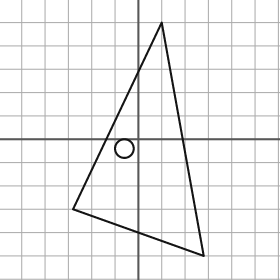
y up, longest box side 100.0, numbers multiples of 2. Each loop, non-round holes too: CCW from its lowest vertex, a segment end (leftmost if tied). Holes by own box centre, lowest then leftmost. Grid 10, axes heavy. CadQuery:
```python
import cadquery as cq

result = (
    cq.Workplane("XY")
    .moveTo(28.0, -50.0)
    .lineTo(10.0, 50.0)
    .lineTo(-28.0, -30.0)
    .close()
    .moveTo(-6.0, -4.0)
    .circle(4.0)
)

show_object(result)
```